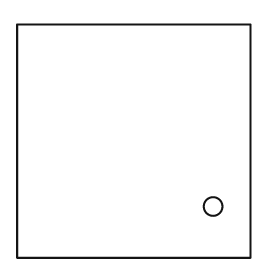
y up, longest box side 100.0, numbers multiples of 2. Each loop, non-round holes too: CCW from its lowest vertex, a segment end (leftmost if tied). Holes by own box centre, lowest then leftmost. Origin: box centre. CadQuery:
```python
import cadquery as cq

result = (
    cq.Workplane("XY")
    .moveTo(-50.0, -50.0)
    .lineTo(50.0, -50.0)
    .lineTo(50.0, 50.0)
    .lineTo(-50.0, 50.0)
    .close()
    .moveTo(34.0, -28.0)
    .circle(4.0)
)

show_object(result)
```